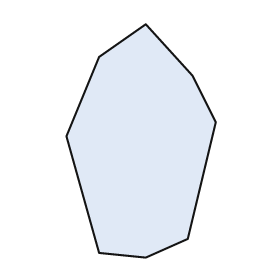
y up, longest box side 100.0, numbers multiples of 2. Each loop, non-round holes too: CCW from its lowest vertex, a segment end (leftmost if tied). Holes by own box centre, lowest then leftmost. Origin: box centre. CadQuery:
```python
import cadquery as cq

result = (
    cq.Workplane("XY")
    .moveTo(2.0, -50.0)
    .lineTo(20.0, -42.0)
    .lineTo(32.0, 8.0)
    .lineTo(22.0, 28.0)
    .lineTo(2.0, 50.0)
    .lineTo(-18.0, 36.0)
    .lineTo(-32.0, 2.0)
    .lineTo(-18.0, -48.0)
    .close()
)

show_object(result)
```